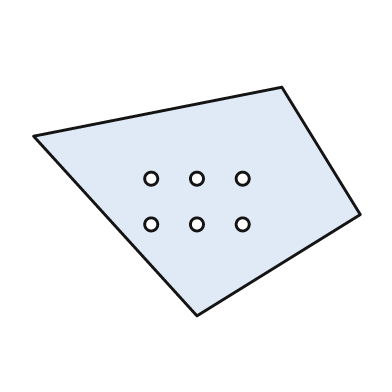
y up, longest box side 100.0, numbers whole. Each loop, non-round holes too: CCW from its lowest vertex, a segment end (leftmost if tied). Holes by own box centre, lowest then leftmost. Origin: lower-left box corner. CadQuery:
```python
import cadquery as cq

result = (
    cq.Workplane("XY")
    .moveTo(50.0, 0.0)
    .lineTo(100.0, 31.0)
    .lineTo(76.0, 70.0)
    .lineTo(0.0, 55.0)
    .close()
    .moveTo(36.0, 28.0)
    .circle(2.0)
    .moveTo(50.0, 28.0)
    .circle(2.0)
    .moveTo(64.0, 28.0)
    .circle(2.0)
    .moveTo(36.0, 42.0)
    .circle(2.0)
    .moveTo(50.0, 42.0)
    .circle(2.0)
    .moveTo(64.0, 42.0)
    .circle(2.0)
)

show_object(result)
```